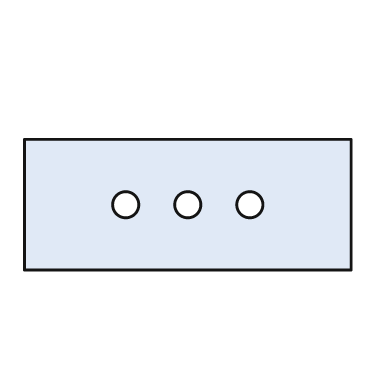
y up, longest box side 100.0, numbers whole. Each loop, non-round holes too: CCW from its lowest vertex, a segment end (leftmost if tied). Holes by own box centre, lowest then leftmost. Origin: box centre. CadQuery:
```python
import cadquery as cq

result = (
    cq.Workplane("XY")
    .moveTo(-50.0, -20.0)
    .lineTo(50.0, -20.0)
    .lineTo(50.0, 20.0)
    .lineTo(-50.0, 20.0)
    .close()
    .moveTo(-19.0, 0.0)
    .circle(4.0)
    .moveTo(0.0, 0.0)
    .circle(4.0)
    .moveTo(19.0, 0.0)
    .circle(4.0)
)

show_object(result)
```